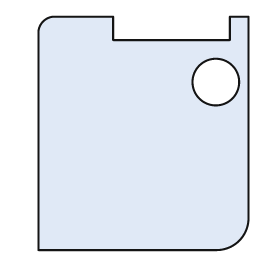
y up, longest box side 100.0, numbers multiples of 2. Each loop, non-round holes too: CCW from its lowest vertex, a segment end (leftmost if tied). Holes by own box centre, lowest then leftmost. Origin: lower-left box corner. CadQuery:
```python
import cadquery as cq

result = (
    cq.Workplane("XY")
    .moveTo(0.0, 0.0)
    .lineTo(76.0, 0.0)
    .threePointArc((86.0, 4.0), (90.0, 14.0))
    .lineTo(90.0, 100.0)
    .lineTo(82.0, 100.0)
    .lineTo(82.0, 90.0)
    .lineTo(32.0, 90.0)
    .lineTo(32.0, 100.0)
    .lineTo(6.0, 100.0)
    .threePointArc((2.0, 98.0), (0.0, 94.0))
    .close()
    .moveTo(76.0, 72.0)
    .circle(10.0)
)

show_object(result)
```